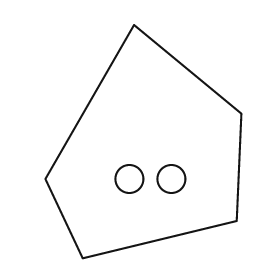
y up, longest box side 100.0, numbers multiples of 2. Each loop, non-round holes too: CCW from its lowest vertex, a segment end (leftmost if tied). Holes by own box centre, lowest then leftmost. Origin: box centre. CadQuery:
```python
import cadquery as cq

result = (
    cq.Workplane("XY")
    .moveTo(-26.0, -50.0)
    .lineTo(40.0, -34.0)
    .lineTo(42.0, 12.0)
    .lineTo(-4.0, 50.0)
    .lineTo(-42.0, -16.0)
    .close()
    .moveTo(-6.0, -16.0)
    .circle(6.0)
    .moveTo(12.0, -16.0)
    .circle(6.0)
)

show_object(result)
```